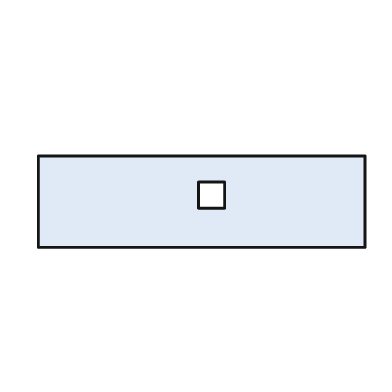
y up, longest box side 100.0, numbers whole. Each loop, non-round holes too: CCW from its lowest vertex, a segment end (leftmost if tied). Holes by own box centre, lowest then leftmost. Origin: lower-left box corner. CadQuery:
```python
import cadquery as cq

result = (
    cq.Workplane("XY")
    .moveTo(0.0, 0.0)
    .lineTo(100.0, 0.0)
    .lineTo(100.0, 28.0)
    .lineTo(0.0, 28.0)
    .close()
    .moveTo(49.0, 12.0)
    .lineTo(57.0, 12.0)
    .lineTo(57.0, 20.0)
    .lineTo(49.0, 20.0)
    .close()
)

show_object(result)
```